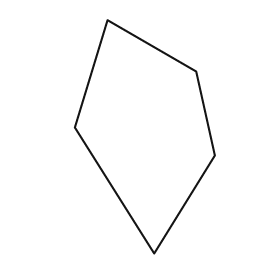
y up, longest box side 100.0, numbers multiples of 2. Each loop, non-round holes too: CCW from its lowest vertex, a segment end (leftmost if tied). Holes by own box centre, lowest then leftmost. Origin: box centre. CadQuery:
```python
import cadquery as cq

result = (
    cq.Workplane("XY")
    .moveTo(4.0, -50.0)
    .lineTo(30.0, -8.0)
    .lineTo(22.0, 28.0)
    .lineTo(-16.0, 50.0)
    .lineTo(-30.0, 4.0)
    .close()
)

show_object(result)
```